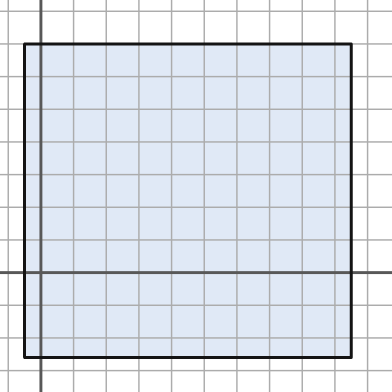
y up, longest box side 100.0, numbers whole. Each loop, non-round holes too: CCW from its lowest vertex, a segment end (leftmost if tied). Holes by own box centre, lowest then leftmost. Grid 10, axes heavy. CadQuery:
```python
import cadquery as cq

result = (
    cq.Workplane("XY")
    .moveTo(-5.0, -26.0)
    .lineTo(95.0, -26.0)
    .lineTo(95.0, 70.0)
    .lineTo(-5.0, 70.0)
    .close()
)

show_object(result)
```